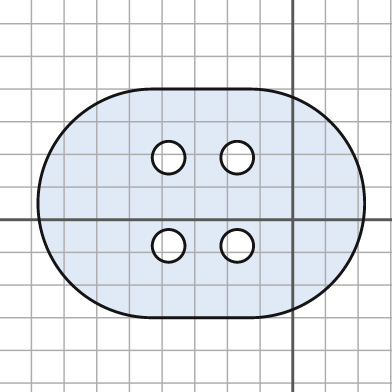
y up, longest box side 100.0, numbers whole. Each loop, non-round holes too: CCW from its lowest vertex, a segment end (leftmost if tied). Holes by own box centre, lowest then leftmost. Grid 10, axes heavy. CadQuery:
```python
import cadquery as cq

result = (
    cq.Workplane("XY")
    .moveTo(-43.0, -30.0)
    .lineTo(-13.0, -30.0)
    .threePointArc((22.0, 5.0), (-13.0, 40.0))
    .lineTo(-43.0, 40.0)
    .threePointArc((-78.0, 5.0), (-43.0, -30.0))
    .close()
    .moveTo(-38.0, -8.0)
    .circle(5.0)
    .moveTo(-17.0, -8.0)
    .circle(5.0)
    .moveTo(-38.0, 19.0)
    .circle(5.0)
    .moveTo(-17.0, 19.0)
    .circle(5.0)
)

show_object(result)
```